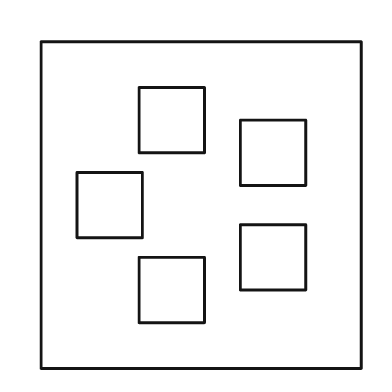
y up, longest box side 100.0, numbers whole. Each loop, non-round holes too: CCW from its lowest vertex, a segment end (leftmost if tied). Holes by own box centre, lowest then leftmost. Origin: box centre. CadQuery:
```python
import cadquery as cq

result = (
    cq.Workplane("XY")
    .moveTo(-49.0, -50.0)
    .lineTo(49.0, -50.0)
    .lineTo(49.0, 50.0)
    .lineTo(-49.0, 50.0)
    .close()
    .moveTo(-19.0, -36.0)
    .lineTo(1.0, -36.0)
    .lineTo(1.0, -16.0)
    .lineTo(-19.0, -16.0)
    .close()
    .moveTo(12.0, -26.0)
    .lineTo(32.0, -26.0)
    .lineTo(32.0, -6.0)
    .lineTo(12.0, -6.0)
    .close()
    .moveTo(-38.0, -10.0)
    .lineTo(-18.0, -10.0)
    .lineTo(-18.0, 10.0)
    .lineTo(-38.0, 10.0)
    .close()
    .moveTo(12.0, 6.0)
    .lineTo(32.0, 6.0)
    .lineTo(32.0, 26.0)
    .lineTo(12.0, 26.0)
    .close()
    .moveTo(-19.0, 16.0)
    .lineTo(1.0, 16.0)
    .lineTo(1.0, 36.0)
    .lineTo(-19.0, 36.0)
    .close()
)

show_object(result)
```